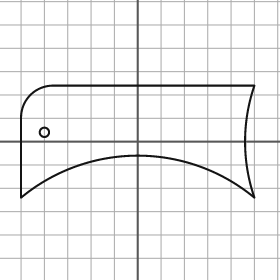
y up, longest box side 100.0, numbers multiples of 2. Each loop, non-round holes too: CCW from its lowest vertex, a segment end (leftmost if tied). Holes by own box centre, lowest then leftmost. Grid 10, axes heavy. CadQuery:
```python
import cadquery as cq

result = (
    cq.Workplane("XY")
    .moveTo(-50.0, -24.0)
    .threePointArc((0.0, -6.0), (50.0, -24.0))
    .threePointArc((46.0, 0.0), (50.0, 24.0))
    .lineTo(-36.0, 24.0)
    .threePointArc((-46.0, 20.0), (-50.0, 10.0))
    .close()
    .moveTo(-40.0, 4.0)
    .circle(2.0)
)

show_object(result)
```